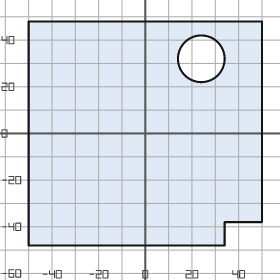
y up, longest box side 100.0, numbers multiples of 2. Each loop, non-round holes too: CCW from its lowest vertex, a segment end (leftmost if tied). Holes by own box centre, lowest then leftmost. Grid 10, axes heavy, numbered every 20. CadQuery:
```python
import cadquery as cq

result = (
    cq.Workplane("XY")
    .moveTo(-50.0, -48.0)
    .lineTo(34.0, -48.0)
    .lineTo(34.0, -38.0)
    .lineTo(50.0, -38.0)
    .lineTo(50.0, 48.0)
    .lineTo(-50.0, 48.0)
    .close()
    .moveTo(24.0, 32.0)
    .circle(10.0)
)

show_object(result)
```